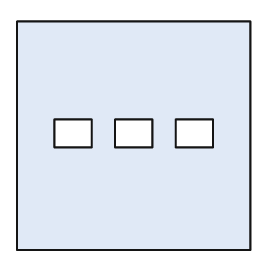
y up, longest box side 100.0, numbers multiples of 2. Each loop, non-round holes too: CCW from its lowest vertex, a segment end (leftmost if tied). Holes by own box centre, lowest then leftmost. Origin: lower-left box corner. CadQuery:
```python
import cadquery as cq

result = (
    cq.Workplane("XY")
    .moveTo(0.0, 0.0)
    .lineTo(100.0, 0.0)
    .lineTo(100.0, 98.0)
    .lineTo(0.0, 98.0)
    .close()
    .moveTo(16.0, 44.0)
    .lineTo(32.0, 44.0)
    .lineTo(32.0, 56.0)
    .lineTo(16.0, 56.0)
    .close()
    .moveTo(42.0, 44.0)
    .lineTo(58.0, 44.0)
    .lineTo(58.0, 56.0)
    .lineTo(42.0, 56.0)
    .close()
    .moveTo(68.0, 44.0)
    .lineTo(84.0, 44.0)
    .lineTo(84.0, 56.0)
    .lineTo(68.0, 56.0)
    .close()
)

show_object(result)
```